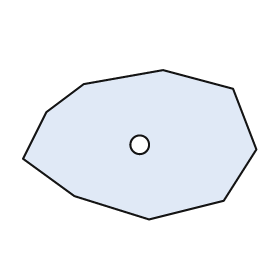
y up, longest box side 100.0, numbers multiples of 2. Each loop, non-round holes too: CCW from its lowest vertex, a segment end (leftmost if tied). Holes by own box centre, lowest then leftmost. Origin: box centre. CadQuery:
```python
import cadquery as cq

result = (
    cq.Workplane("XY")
    .moveTo(4.0, -32.0)
    .lineTo(36.0, -24.0)
    .lineTo(50.0, -2.0)
    .lineTo(40.0, 24.0)
    .lineTo(10.0, 32.0)
    .lineTo(-24.0, 26.0)
    .lineTo(-40.0, 14.0)
    .lineTo(-50.0, -6.0)
    .lineTo(-28.0, -22.0)
    .close()
    .moveTo(0.0, 0.0)
    .circle(4.0)
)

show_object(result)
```